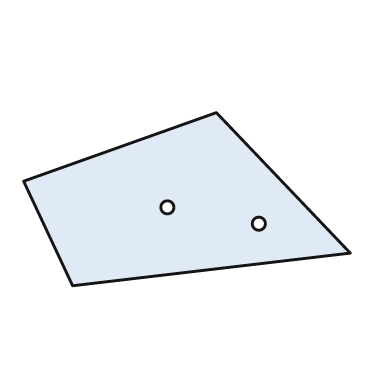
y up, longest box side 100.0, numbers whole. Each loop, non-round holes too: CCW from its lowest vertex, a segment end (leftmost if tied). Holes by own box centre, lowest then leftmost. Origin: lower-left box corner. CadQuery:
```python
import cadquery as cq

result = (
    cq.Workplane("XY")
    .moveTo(15.0, 0.0)
    .lineTo(100.0, 10.0)
    .lineTo(59.0, 53.0)
    .lineTo(0.0, 32.0)
    .close()
    .moveTo(72.0, 19.0)
    .circle(2.0)
    .moveTo(44.0, 24.0)
    .circle(2.0)
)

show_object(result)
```